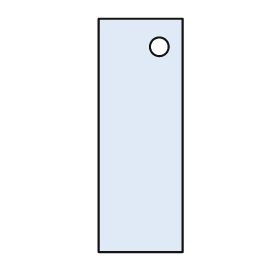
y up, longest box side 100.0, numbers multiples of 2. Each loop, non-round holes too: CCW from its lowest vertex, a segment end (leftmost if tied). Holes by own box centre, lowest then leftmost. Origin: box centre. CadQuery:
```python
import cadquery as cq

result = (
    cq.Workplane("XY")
    .moveTo(-18.0, -50.0)
    .lineTo(18.0, -50.0)
    .lineTo(18.0, 50.0)
    .lineTo(-18.0, 50.0)
    .close()
    .moveTo(8.0, 38.0)
    .circle(4.0)
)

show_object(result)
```